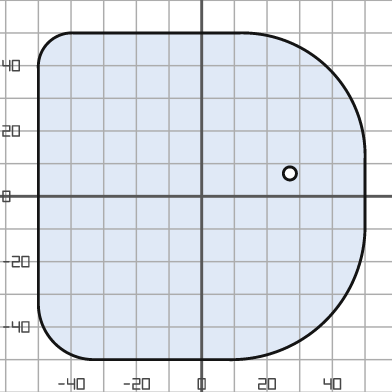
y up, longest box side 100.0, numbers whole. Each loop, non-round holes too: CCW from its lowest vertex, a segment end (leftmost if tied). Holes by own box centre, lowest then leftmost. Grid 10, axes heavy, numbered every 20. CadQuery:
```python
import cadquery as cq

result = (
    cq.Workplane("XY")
    .moveTo(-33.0, -50.0)
    .lineTo(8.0, -50.0)
    .threePointArc((38.0, -38.0), (50.0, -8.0))
    .lineTo(50.0, 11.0)
    .threePointArc((39.0, 39.0), (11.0, 50.0))
    .lineTo(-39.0, 50.0)
    .threePointArc((-47.0, 47.0), (-50.0, 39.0))
    .lineTo(-50.0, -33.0)
    .threePointArc((-45.0, -45.0), (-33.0, -50.0))
    .close()
    .moveTo(27.0, 7.0)
    .circle(2.0)
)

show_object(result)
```